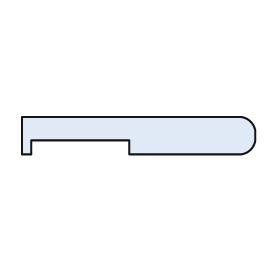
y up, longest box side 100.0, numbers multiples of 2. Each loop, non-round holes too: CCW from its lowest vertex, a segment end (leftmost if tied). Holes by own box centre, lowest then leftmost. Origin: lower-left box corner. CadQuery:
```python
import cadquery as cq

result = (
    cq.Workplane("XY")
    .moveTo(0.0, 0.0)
    .lineTo(4.0, 0.0)
    .lineTo(4.0, 6.0)
    .lineTo(46.0, 6.0)
    .lineTo(46.0, 0.0)
    .lineTo(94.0, 0.0)
    .threePointArc((98.0, 2.0), (100.0, 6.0))
    .lineTo(100.0, 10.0)
    .threePointArc((98.0, 14.0), (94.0, 16.0))
    .lineTo(0.0, 16.0)
    .close()
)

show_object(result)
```